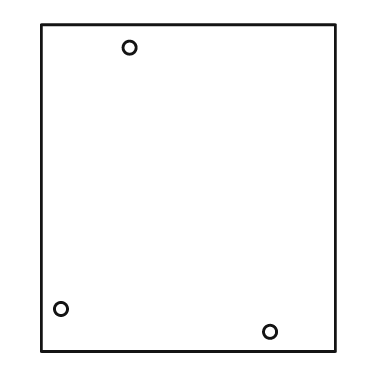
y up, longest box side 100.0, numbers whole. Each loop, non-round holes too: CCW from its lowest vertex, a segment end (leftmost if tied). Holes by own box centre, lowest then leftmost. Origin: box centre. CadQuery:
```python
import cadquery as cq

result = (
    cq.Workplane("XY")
    .moveTo(-45.0, -50.0)
    .lineTo(45.0, -50.0)
    .lineTo(45.0, 50.0)
    .lineTo(-45.0, 50.0)
    .close()
    .moveTo(25.0, -44.0)
    .circle(2.0)
    .moveTo(-39.0, -37.0)
    .circle(2.0)
    .moveTo(-18.0, 43.0)
    .circle(2.0)
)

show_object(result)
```